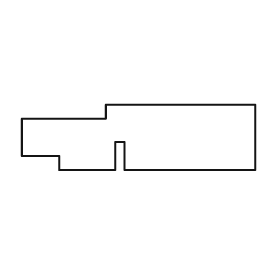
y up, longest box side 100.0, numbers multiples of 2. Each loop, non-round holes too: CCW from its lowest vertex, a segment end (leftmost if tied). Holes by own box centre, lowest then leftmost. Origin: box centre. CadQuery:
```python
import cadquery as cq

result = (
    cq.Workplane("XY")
    .moveTo(-34.0, -14.0)
    .lineTo(-10.0, -14.0)
    .lineTo(-10.0, -2.0)
    .lineTo(-6.0, -2.0)
    .lineTo(-6.0, -14.0)
    .lineTo(50.0, -14.0)
    .lineTo(50.0, 14.0)
    .lineTo(-14.0, 14.0)
    .lineTo(-14.0, 8.0)
    .lineTo(-50.0, 8.0)
    .lineTo(-50.0, -8.0)
    .lineTo(-34.0, -8.0)
    .close()
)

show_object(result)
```